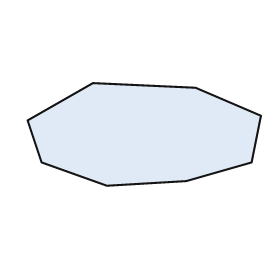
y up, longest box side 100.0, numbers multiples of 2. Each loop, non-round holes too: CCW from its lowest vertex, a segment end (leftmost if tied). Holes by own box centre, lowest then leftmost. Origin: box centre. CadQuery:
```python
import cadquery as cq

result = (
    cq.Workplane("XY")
    .moveTo(-16.0, -22.0)
    .lineTo(18.0, -20.0)
    .lineTo(46.0, -12.0)
    .lineTo(50.0, 8.0)
    .lineTo(22.0, 20.0)
    .lineTo(-22.0, 22.0)
    .lineTo(-50.0, 6.0)
    .lineTo(-44.0, -12.0)
    .close()
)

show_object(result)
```